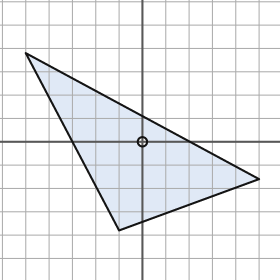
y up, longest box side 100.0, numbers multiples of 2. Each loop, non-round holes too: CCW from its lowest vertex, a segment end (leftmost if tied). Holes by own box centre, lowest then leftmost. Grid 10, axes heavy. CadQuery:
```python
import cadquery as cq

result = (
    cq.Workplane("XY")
    .moveTo(-10.0, -38.0)
    .lineTo(50.0, -16.0)
    .lineTo(-50.0, 38.0)
    .close()
    .moveTo(0.0, 0.0)
    .circle(2.0)
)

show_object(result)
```